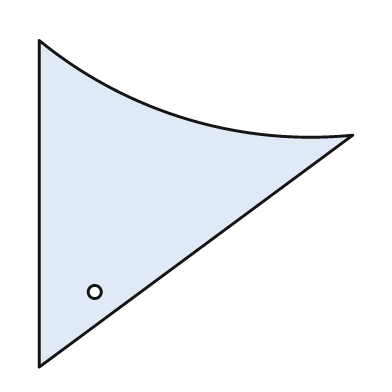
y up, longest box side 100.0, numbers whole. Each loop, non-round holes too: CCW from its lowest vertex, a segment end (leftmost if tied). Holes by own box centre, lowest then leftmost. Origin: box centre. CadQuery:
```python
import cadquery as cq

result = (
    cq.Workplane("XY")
    .moveTo(-48.0, -50.0)
    .lineTo(48.0, 21.0)
    .threePointArc((-3.0, 26.0), (-48.0, 50.0))
    .close()
    .moveTo(-31.0, -27.0)
    .circle(2.0)
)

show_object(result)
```